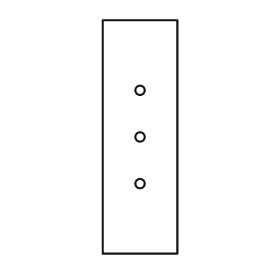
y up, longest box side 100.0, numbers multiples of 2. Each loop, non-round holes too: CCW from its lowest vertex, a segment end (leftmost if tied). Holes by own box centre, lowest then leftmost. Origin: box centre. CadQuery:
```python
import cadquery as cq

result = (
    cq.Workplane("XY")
    .moveTo(-16.0, -50.0)
    .lineTo(16.0, -50.0)
    .lineTo(16.0, 50.0)
    .lineTo(-16.0, 50.0)
    .close()
    .moveTo(0.0, -20.0)
    .circle(2.0)
    .moveTo(0.0, 0.0)
    .circle(2.0)
    .moveTo(0.0, 20.0)
    .circle(2.0)
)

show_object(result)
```